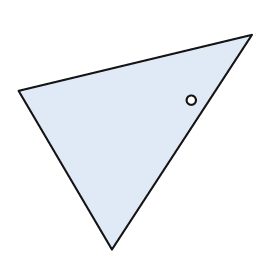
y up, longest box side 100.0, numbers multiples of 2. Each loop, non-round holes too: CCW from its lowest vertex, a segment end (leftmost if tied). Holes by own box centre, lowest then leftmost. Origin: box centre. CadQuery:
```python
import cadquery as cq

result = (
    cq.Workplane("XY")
    .moveTo(-10.0, -46.0)
    .lineTo(50.0, 46.0)
    .lineTo(-50.0, 22.0)
    .close()
    .moveTo(24.0, 18.0)
    .circle(2.0)
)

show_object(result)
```